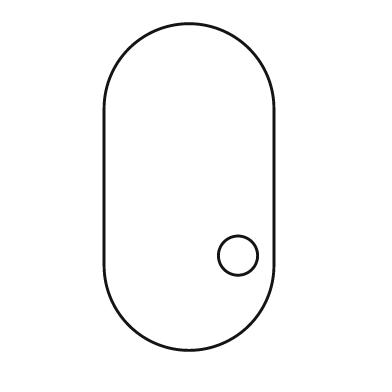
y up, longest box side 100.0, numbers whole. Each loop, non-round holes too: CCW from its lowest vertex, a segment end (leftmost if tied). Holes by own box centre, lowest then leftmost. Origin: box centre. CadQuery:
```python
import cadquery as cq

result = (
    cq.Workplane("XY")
    .moveTo(-26.0, -24.0)
    .threePointArc((0.0, -50.0), (26.0, -24.0))
    .lineTo(26.0, 24.0)
    .threePointArc((0.0, 50.0), (-26.0, 24.0))
    .close()
    .moveTo(15.0, -21.0)
    .circle(6.0)
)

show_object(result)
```